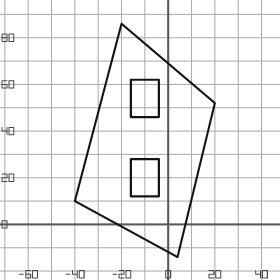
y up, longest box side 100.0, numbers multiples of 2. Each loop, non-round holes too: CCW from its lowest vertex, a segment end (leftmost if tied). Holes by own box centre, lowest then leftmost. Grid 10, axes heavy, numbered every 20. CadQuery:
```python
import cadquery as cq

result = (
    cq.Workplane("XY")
    .moveTo(4.0, -14.0)
    .lineTo(20.0, 52.0)
    .lineTo(-20.0, 86.0)
    .lineTo(-40.0, 10.0)
    .close()
    .moveTo(-16.0, 12.0)
    .lineTo(-4.0, 12.0)
    .lineTo(-4.0, 28.0)
    .lineTo(-16.0, 28.0)
    .close()
    .moveTo(-16.0, 46.0)
    .lineTo(-4.0, 46.0)
    .lineTo(-4.0, 62.0)
    .lineTo(-16.0, 62.0)
    .close()
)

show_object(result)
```